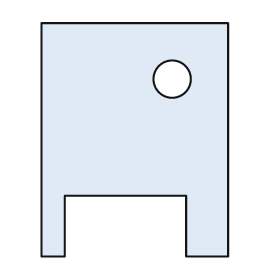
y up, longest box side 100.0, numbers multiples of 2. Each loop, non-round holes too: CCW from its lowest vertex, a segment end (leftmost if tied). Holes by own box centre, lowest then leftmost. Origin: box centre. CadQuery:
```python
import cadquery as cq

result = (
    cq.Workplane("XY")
    .moveTo(-40.0, -50.0)
    .lineTo(-30.0, -50.0)
    .lineTo(-30.0, -24.0)
    .lineTo(22.0, -24.0)
    .lineTo(22.0, -50.0)
    .lineTo(40.0, -50.0)
    .lineTo(40.0, 50.0)
    .lineTo(-40.0, 50.0)
    .close()
    .moveTo(16.0, 26.0)
    .circle(8.0)
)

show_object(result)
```